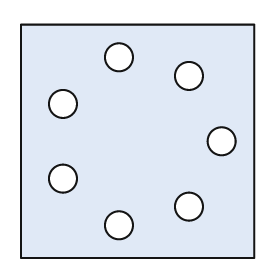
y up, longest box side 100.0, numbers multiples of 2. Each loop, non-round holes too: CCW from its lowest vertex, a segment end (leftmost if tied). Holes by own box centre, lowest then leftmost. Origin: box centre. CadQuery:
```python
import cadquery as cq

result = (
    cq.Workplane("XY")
    .moveTo(-50.0, -50.0)
    .lineTo(50.0, -50.0)
    .lineTo(50.0, 50.0)
    .lineTo(-50.0, 50.0)
    .close()
    .moveTo(-8.0, -36.0)
    .circle(6.0)
    .moveTo(22.0, -28.0)
    .circle(6.0)
    .moveTo(-32.0, -16.0)
    .circle(6.0)
    .moveTo(36.0, 0.0)
    .circle(6.0)
    .moveTo(-32.0, 16.0)
    .circle(6.0)
    .moveTo(22.0, 28.0)
    .circle(6.0)
    .moveTo(-8.0, 36.0)
    .circle(6.0)
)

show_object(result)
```